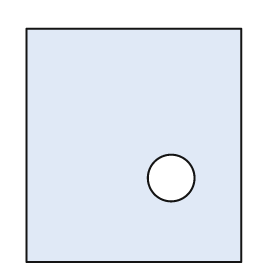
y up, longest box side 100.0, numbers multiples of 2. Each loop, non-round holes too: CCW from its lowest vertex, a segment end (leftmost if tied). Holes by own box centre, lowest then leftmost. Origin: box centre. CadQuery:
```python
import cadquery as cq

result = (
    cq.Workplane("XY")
    .moveTo(-46.0, -50.0)
    .lineTo(46.0, -50.0)
    .lineTo(46.0, 50.0)
    .lineTo(-46.0, 50.0)
    .close()
    .moveTo(16.0, -14.0)
    .circle(10.0)
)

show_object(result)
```